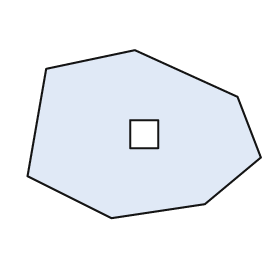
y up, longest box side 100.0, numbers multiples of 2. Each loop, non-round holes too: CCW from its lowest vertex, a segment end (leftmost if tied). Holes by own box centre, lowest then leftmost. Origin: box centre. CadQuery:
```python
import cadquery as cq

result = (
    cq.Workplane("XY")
    .moveTo(-14.0, -36.0)
    .lineTo(26.0, -30.0)
    .lineTo(50.0, -10.0)
    .lineTo(40.0, 16.0)
    .lineTo(-4.0, 36.0)
    .lineTo(-42.0, 28.0)
    .lineTo(-50.0, -18.0)
    .close()
    .moveTo(-6.0, -6.0)
    .lineTo(6.0, -6.0)
    .lineTo(6.0, 6.0)
    .lineTo(-6.0, 6.0)
    .close()
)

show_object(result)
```